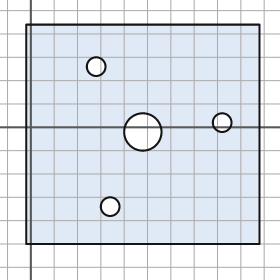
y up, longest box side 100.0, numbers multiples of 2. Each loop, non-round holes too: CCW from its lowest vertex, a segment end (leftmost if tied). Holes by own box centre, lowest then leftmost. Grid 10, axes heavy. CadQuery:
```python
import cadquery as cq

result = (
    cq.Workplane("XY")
    .moveTo(-2.0, -50.0)
    .lineTo(98.0, -50.0)
    .lineTo(98.0, 44.0)
    .lineTo(-2.0, 44.0)
    .close()
    .moveTo(34.0, -34.0)
    .circle(4.0)
    .moveTo(48.0, -2.0)
    .circle(8.0)
    .moveTo(82.0, 2.0)
    .circle(4.0)
    .moveTo(28.0, 26.0)
    .circle(4.0)
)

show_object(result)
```